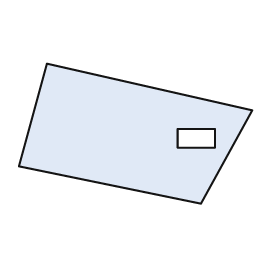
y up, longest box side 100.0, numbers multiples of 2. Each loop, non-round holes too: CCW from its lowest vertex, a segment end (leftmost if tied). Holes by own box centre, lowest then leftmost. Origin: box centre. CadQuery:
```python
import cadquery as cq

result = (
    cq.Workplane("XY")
    .moveTo(28.0, -30.0)
    .lineTo(50.0, 10.0)
    .lineTo(-38.0, 30.0)
    .lineTo(-50.0, -14.0)
    .close()
    .moveTo(18.0, -6.0)
    .lineTo(34.0, -6.0)
    .lineTo(34.0, 2.0)
    .lineTo(18.0, 2.0)
    .close()
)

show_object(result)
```